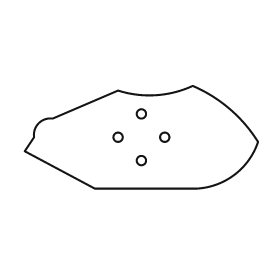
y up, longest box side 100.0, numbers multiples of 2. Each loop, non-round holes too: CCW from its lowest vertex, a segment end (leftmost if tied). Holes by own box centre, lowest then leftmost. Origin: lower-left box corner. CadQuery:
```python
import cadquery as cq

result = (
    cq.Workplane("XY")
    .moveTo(30.0, 0.0)
    .lineTo(74.0, 0.0)
    .threePointArc((90.0, 6.0), (100.0, 20.0))
    .threePointArc((88.0, 34.0), (72.0, 44.0))
    .threePointArc((56.0, 40.0), (40.0, 42.0))
    .lineTo(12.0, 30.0)
    .threePointArc((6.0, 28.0), (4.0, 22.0))
    .lineTo(0.0, 16.0)
    .close()
    .moveTo(50.0, 12.0)
    .circle(2.0)
    .moveTo(40.0, 22.0)
    .circle(2.0)
    .moveTo(60.0, 22.0)
    .circle(2.0)
    .moveTo(50.0, 32.0)
    .circle(2.0)
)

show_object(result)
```